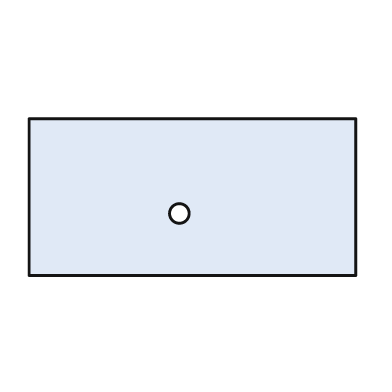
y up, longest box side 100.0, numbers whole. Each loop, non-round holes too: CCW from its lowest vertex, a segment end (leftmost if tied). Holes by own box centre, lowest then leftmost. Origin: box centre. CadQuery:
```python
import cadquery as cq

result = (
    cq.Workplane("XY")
    .moveTo(-50.0, -24.0)
    .lineTo(50.0, -24.0)
    .lineTo(50.0, 24.0)
    .lineTo(-50.0, 24.0)
    .close()
    .moveTo(-4.0, -5.0)
    .circle(3.0)
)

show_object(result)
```